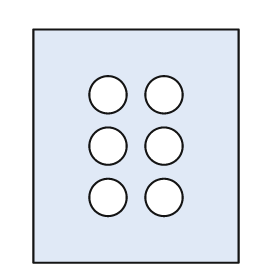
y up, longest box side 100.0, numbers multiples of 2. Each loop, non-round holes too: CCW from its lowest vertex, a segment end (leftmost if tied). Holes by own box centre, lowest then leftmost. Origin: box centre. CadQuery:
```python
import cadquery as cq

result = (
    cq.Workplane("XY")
    .moveTo(-44.0, -50.0)
    .lineTo(44.0, -50.0)
    .lineTo(44.0, 50.0)
    .lineTo(-44.0, 50.0)
    .close()
    .moveTo(-12.0, -22.0)
    .circle(8.0)
    .moveTo(12.0, -22.0)
    .circle(8.0)
    .moveTo(-12.0, 0.0)
    .circle(8.0)
    .moveTo(12.0, 0.0)
    .circle(8.0)
    .moveTo(-12.0, 22.0)
    .circle(8.0)
    .moveTo(12.0, 22.0)
    .circle(8.0)
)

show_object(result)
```